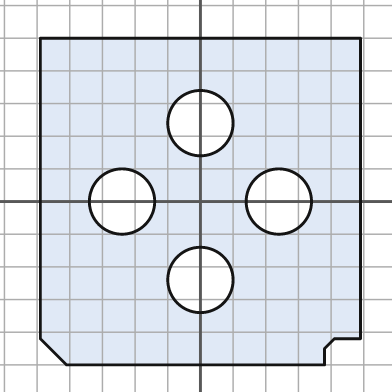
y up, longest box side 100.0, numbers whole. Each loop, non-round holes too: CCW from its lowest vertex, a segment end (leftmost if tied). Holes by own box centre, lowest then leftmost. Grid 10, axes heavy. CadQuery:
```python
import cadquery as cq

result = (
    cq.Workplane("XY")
    .moveTo(-41.0, -50.0)
    .lineTo(38.0, -50.0)
    .lineTo(38.0, -45.0)
    .lineTo(41.0, -42.0)
    .lineTo(49.0, -42.0)
    .lineTo(49.0, 50.0)
    .lineTo(-49.0, 50.0)
    .lineTo(-49.0, -42.0)
    .close()
    .moveTo(0.0, -24.0)
    .circle(10.0)
    .moveTo(-24.0, 0.0)
    .circle(10.0)
    .moveTo(24.0, 0.0)
    .circle(10.0)
    .moveTo(0.0, 24.0)
    .circle(10.0)
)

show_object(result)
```